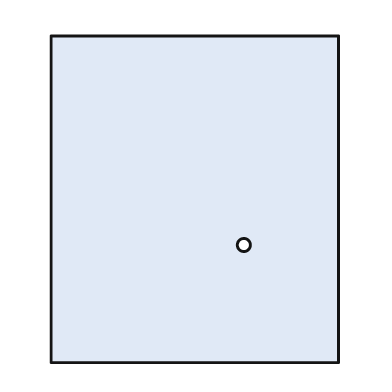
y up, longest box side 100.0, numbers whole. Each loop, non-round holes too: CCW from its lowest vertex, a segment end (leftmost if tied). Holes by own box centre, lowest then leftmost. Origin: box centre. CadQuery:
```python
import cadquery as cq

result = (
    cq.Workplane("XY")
    .moveTo(-44.0, -50.0)
    .lineTo(44.0, -50.0)
    .lineTo(44.0, 50.0)
    .lineTo(-44.0, 50.0)
    .close()
    .moveTo(15.0, -14.0)
    .circle(2.0)
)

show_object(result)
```